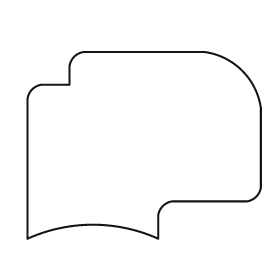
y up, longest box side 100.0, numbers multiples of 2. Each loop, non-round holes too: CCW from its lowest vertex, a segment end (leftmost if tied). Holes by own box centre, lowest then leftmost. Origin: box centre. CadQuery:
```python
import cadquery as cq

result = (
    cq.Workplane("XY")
    .moveTo(-50.0, -40.0)
    .threePointArc((-22.0, -34.0), (6.0, -40.0))
    .lineTo(6.0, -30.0)
    .threePointArc((8.0, -26.0), (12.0, -24.0))
    .lineTo(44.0, -24.0)
    .threePointArc((48.0, -22.0), (50.0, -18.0))
    .lineTo(50.0, 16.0)
    .threePointArc((42.0, 32.0), (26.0, 40.0))
    .lineTo(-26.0, 40.0)
    .threePointArc((-30.0, 38.0), (-32.0, 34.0))
    .lineTo(-32.0, 26.0)
    .lineTo(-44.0, 26.0)
    .threePointArc((-48.0, 24.0), (-50.0, 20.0))
    .close()
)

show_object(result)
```